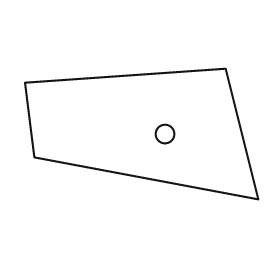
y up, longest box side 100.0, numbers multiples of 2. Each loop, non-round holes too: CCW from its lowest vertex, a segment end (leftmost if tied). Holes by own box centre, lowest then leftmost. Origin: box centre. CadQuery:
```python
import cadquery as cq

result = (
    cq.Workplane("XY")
    .moveTo(50.0, -28.0)
    .lineTo(36.0, 28.0)
    .lineTo(-50.0, 22.0)
    .lineTo(-46.0, -10.0)
    .close()
    .moveTo(10.0, 0.0)
    .circle(4.0)
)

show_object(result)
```